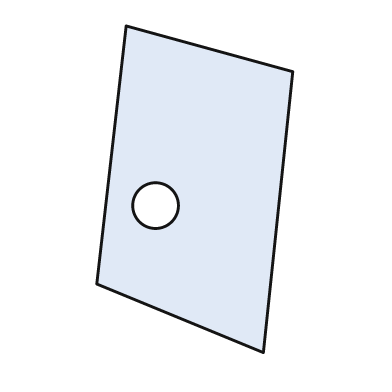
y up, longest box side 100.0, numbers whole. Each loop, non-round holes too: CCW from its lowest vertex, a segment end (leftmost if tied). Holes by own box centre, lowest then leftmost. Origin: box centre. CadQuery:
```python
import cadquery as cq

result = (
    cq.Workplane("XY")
    .moveTo(21.0, -50.0)
    .lineTo(30.0, 36.0)
    .lineTo(-21.0, 50.0)
    .lineTo(-30.0, -29.0)
    .close()
    .moveTo(-12.0, -5.0)
    .circle(7.0)
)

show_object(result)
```